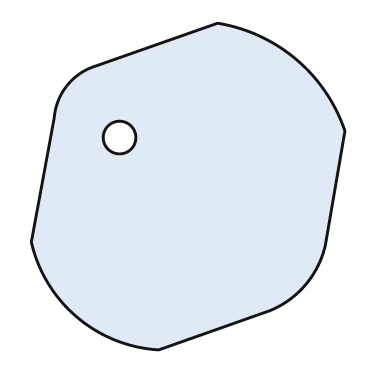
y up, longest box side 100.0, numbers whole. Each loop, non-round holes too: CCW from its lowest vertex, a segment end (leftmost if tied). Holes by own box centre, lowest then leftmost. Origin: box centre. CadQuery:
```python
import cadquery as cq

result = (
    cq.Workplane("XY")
    .moveTo(-9.0, -50.0)
    .lineTo(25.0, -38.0)
    .threePointArc((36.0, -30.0), (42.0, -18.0))
    .lineTo(48.0, 17.0)
    .threePointArc((33.0, 39.0), (9.0, 50.0))
    .lineTo(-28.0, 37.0)
    .threePointArc((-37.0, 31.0), (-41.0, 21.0))
    .lineTo(-48.0, -17.0)
    .threePointArc((-34.0, -40.0), (-9.0, -50.0))
    .close()
    .moveTo(-21.0, 15.0)
    .circle(5.0)
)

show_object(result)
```